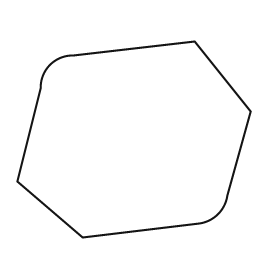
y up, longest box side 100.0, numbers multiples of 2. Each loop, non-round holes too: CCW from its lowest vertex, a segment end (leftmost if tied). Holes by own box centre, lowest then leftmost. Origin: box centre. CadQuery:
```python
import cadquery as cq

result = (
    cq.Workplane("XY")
    .moveTo(-22.0, -42.0)
    .lineTo(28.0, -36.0)
    .threePointArc((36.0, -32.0), (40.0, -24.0))
    .lineTo(50.0, 12.0)
    .lineTo(26.0, 42.0)
    .lineTo(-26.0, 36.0)
    .threePointArc((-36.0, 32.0), (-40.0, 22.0))
    .lineTo(-50.0, -18.0)
    .close()
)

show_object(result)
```